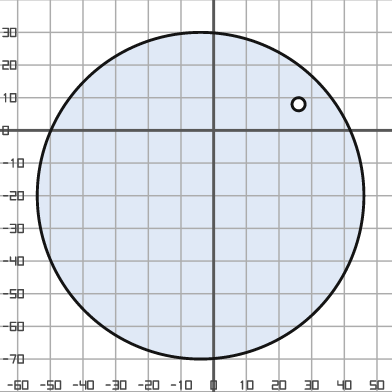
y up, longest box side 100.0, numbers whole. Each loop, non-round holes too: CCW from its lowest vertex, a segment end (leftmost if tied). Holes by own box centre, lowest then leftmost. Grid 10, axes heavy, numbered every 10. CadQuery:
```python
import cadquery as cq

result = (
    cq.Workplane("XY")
    .moveTo(-4.0, -20.0)
    .circle(50.0)
    .moveTo(26.0, 8.0)
    .circle(2.0)
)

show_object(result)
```